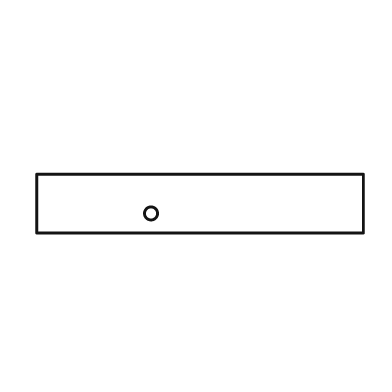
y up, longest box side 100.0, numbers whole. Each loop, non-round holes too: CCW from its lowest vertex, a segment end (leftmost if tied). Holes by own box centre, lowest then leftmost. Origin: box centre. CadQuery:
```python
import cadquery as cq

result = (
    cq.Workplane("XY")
    .moveTo(-50.0, -9.0)
    .lineTo(50.0, -9.0)
    .lineTo(50.0, 9.0)
    .lineTo(-50.0, 9.0)
    .close()
    .moveTo(-15.0, -3.0)
    .circle(2.0)
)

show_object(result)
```